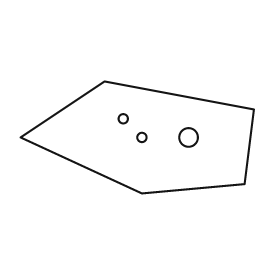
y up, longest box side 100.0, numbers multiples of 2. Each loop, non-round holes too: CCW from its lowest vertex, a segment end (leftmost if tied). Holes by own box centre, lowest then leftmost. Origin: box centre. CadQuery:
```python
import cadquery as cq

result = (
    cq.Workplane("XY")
    .moveTo(2.0, -24.0)
    .lineTo(46.0, -20.0)
    .lineTo(50.0, 12.0)
    .lineTo(-14.0, 24.0)
    .lineTo(-50.0, 0.0)
    .close()
    .moveTo(2.0, 0.0)
    .circle(2.0)
    .moveTo(22.0, 0.0)
    .circle(4.0)
    .moveTo(-6.0, 8.0)
    .circle(2.0)
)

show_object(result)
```